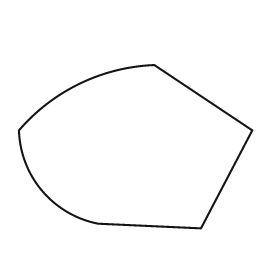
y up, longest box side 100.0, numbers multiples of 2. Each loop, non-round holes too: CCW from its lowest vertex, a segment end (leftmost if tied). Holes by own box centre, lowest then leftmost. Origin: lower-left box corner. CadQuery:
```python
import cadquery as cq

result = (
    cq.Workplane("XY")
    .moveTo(78.0, 0.0)
    .lineTo(100.0, 42.0)
    .lineTo(58.0, 70.0)
    .threePointArc((26.0, 62.0), (0.0, 42.0))
    .threePointArc((10.0, 16.0), (34.0, 2.0))
    .close()
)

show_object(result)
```